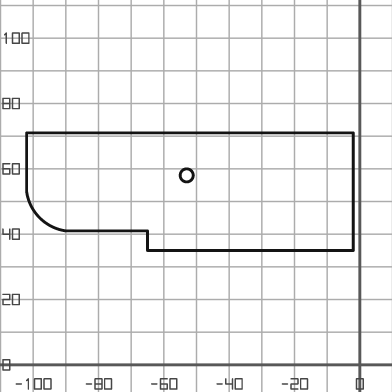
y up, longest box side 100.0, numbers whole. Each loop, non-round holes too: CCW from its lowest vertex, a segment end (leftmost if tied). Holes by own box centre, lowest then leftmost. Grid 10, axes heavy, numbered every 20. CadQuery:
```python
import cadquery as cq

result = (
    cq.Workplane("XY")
    .moveTo(-65.0, 35.0)
    .lineTo(-2.0, 35.0)
    .lineTo(-2.0, 71.0)
    .lineTo(-102.0, 71.0)
    .lineTo(-102.0, 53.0)
    .threePointArc((-98.0, 45.0), (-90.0, 41.0))
    .lineTo(-65.0, 41.0)
    .close()
    .moveTo(-53.0, 58.0)
    .circle(2.0)
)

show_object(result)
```